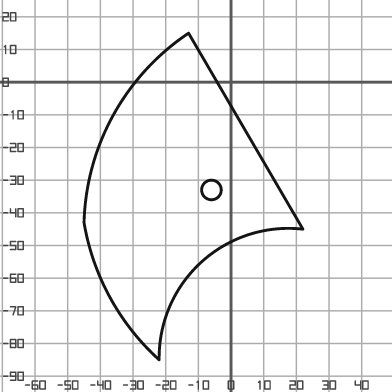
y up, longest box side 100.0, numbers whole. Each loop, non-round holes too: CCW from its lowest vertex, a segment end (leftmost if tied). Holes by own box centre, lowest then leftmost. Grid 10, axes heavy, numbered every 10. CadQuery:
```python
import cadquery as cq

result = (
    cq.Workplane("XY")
    .moveTo(-22.0, -85.0)
    .threePointArc((-9.0, -55.0), (22.0, -45.0))
    .lineTo(-13.0, 15.0)
    .threePointArc((-36.0, -10.0), (-45.0, -43.0))
    .threePointArc((-37.0, -66.0), (-22.0, -85.0))
    .close()
    .moveTo(-6.0, -33.0)
    .circle(3.0)
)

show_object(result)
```